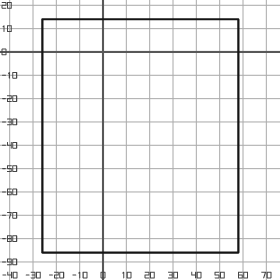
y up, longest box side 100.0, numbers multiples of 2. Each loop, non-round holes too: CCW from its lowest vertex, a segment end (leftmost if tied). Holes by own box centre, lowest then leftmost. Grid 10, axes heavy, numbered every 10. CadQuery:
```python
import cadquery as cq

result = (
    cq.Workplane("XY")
    .moveTo(-26.0, -86.0)
    .lineTo(58.0, -86.0)
    .lineTo(58.0, 14.0)
    .lineTo(-26.0, 14.0)
    .close()
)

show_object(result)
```